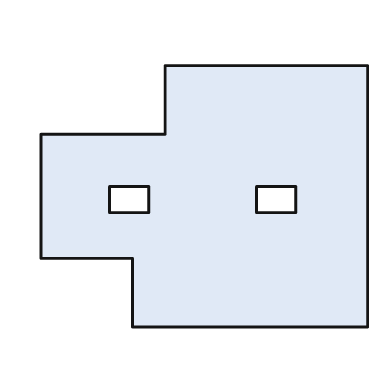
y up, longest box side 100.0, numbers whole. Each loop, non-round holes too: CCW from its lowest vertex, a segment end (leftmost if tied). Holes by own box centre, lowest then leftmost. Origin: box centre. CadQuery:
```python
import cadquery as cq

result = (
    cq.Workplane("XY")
    .moveTo(-22.0, -40.0)
    .lineTo(50.0, -40.0)
    .lineTo(50.0, 40.0)
    .lineTo(-12.0, 40.0)
    .lineTo(-12.0, 19.0)
    .lineTo(-50.0, 19.0)
    .lineTo(-50.0, -19.0)
    .lineTo(-22.0, -19.0)
    .close()
    .moveTo(-29.0, -5.0)
    .lineTo(-17.0, -5.0)
    .lineTo(-17.0, 3.0)
    .lineTo(-29.0, 3.0)
    .close()
    .moveTo(16.0, -5.0)
    .lineTo(28.0, -5.0)
    .lineTo(28.0, 3.0)
    .lineTo(16.0, 3.0)
    .close()
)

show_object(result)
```